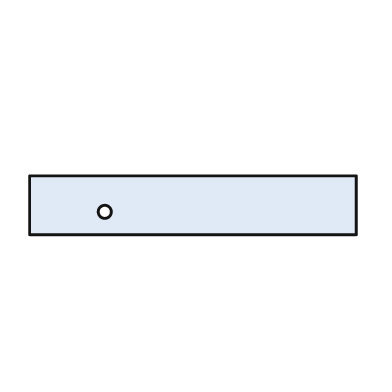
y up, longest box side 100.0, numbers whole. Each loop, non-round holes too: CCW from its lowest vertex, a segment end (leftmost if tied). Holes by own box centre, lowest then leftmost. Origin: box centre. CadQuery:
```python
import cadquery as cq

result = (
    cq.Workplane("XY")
    .moveTo(-50.0, -9.0)
    .lineTo(50.0, -9.0)
    .lineTo(50.0, 9.0)
    .lineTo(-50.0, 9.0)
    .close()
    .moveTo(-27.0, -2.0)
    .circle(2.0)
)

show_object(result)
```